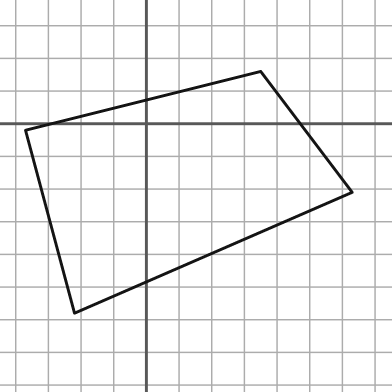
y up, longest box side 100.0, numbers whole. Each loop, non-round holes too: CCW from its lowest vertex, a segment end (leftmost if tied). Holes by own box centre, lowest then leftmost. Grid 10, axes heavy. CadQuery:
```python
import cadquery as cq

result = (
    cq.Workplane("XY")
    .moveTo(-22.0, -58.0)
    .lineTo(63.0, -21.0)
    .lineTo(35.0, 16.0)
    .lineTo(-37.0, -2.0)
    .close()
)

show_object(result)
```